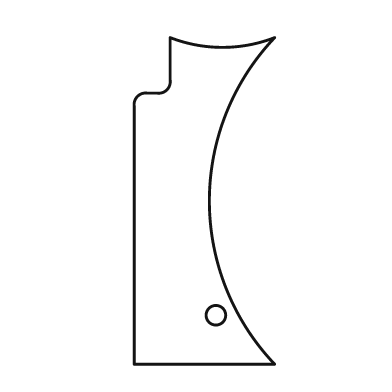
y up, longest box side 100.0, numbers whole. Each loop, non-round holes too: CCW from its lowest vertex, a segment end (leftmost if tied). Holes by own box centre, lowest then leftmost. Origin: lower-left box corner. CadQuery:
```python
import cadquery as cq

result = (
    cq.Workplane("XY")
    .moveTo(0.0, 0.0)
    .lineTo(43.0, 0.0)
    .threePointArc((23.0, 50.0), (43.0, 100.0))
    .threePointArc((27.0, 97.0), (11.0, 100.0))
    .lineTo(11.0, 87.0)
    .threePointArc((10.0, 84.0), (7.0, 83.0))
    .lineTo(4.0, 83.0)
    .threePointArc((1.0, 82.0), (0.0, 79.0))
    .close()
    .moveTo(25.0, 15.0)
    .circle(3.0)
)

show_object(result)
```